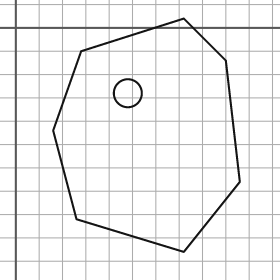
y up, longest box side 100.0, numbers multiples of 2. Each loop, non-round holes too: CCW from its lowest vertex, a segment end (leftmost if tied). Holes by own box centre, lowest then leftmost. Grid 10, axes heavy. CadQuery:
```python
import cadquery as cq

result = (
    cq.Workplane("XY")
    .moveTo(72.0, -96.0)
    .lineTo(96.0, -66.0)
    .lineTo(90.0, -14.0)
    .lineTo(72.0, 4.0)
    .lineTo(28.0, -10.0)
    .lineTo(16.0, -44.0)
    .lineTo(26.0, -82.0)
    .close()
    .moveTo(48.0, -28.0)
    .circle(6.0)
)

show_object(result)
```